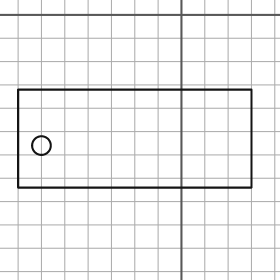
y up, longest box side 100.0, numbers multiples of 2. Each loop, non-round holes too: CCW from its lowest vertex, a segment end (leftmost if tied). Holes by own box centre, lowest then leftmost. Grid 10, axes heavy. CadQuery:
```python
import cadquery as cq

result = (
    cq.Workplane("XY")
    .moveTo(-70.0, -74.0)
    .lineTo(30.0, -74.0)
    .lineTo(30.0, -32.0)
    .lineTo(-70.0, -32.0)
    .close()
    .moveTo(-60.0, -56.0)
    .circle(4.0)
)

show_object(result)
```